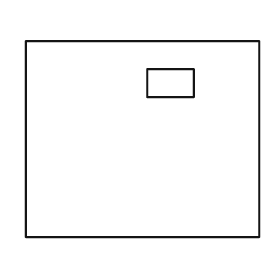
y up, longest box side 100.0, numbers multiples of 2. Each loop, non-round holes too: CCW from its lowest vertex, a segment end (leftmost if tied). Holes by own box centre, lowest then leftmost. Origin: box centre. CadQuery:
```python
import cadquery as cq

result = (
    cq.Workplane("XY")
    .moveTo(-50.0, -42.0)
    .lineTo(50.0, -42.0)
    .lineTo(50.0, 42.0)
    .lineTo(-50.0, 42.0)
    .close()
    .moveTo(2.0, 18.0)
    .lineTo(22.0, 18.0)
    .lineTo(22.0, 30.0)
    .lineTo(2.0, 30.0)
    .close()
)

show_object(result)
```